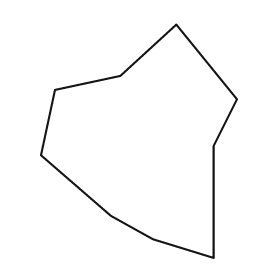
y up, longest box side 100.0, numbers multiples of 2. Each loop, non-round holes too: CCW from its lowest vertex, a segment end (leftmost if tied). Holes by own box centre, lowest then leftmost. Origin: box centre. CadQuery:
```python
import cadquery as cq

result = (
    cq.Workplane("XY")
    .moveTo(32.0, -50.0)
    .lineTo(32.0, -2.0)
    .lineTo(42.0, 18.0)
    .lineTo(16.0, 50.0)
    .lineTo(-8.0, 28.0)
    .lineTo(-36.0, 22.0)
    .lineTo(-42.0, -6.0)
    .lineTo(-12.0, -32.0)
    .lineTo(6.0, -42.0)
    .close()
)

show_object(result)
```